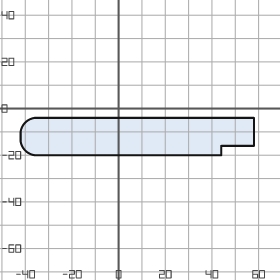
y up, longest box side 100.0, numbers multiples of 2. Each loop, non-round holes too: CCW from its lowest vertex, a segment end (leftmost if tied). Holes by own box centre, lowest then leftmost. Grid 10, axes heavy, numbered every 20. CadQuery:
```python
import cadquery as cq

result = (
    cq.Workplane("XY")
    .moveTo(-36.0, -20.0)
    .lineTo(44.0, -20.0)
    .lineTo(44.0, -16.0)
    .lineTo(58.0, -16.0)
    .lineTo(58.0, -4.0)
    .lineTo(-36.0, -4.0)
    .threePointArc((-40.0, -6.0), (-42.0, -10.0))
    .lineTo(-42.0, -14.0)
    .threePointArc((-40.0, -18.0), (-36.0, -20.0))
    .close()
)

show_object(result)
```